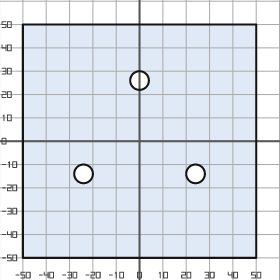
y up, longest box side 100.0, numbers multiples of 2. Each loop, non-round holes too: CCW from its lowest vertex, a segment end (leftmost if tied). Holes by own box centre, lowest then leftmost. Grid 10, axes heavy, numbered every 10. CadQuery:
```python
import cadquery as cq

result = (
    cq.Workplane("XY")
    .moveTo(-50.0, -50.0)
    .lineTo(50.0, -50.0)
    .lineTo(50.0, 50.0)
    .lineTo(-50.0, 50.0)
    .close()
    .moveTo(-24.0, -14.0)
    .circle(4.0)
    .moveTo(24.0, -14.0)
    .circle(4.0)
    .moveTo(0.0, 26.0)
    .circle(4.0)
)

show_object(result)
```